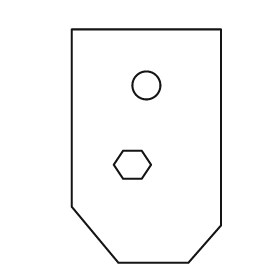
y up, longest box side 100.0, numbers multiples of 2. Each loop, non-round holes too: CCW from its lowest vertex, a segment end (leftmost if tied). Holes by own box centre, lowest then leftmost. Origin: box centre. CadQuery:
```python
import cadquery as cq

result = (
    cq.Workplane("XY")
    .moveTo(-12.0, -50.0)
    .lineTo(18.0, -50.0)
    .lineTo(32.0, -34.0)
    .lineTo(32.0, 50.0)
    .lineTo(-32.0, 50.0)
    .lineTo(-32.0, -26.0)
    .close()
    .moveTo(-10.0, -14.0)
    .lineTo(-2.0, -14.0)
    .lineTo(2.0, -8.0)
    .lineTo(-2.0, -2.0)
    .lineTo(-10.0, -2.0)
    .lineTo(-14.0, -8.0)
    .close()
    .moveTo(0.0, 26.0)
    .circle(6.0)
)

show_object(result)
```